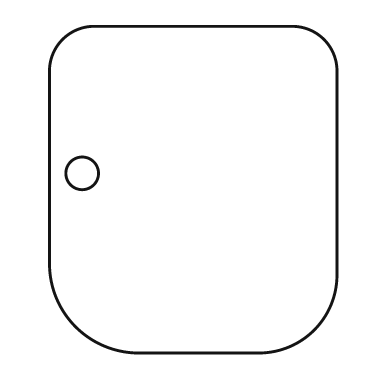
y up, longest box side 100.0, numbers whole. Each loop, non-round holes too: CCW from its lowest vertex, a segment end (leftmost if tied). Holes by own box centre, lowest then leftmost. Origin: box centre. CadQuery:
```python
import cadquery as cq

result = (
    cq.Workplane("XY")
    .moveTo(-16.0, -50.0)
    .lineTo(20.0, -50.0)
    .threePointArc((37.0, -43.0), (44.0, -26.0))
    .lineTo(44.0, 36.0)
    .threePointArc((40.0, 46.0), (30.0, 50.0))
    .lineTo(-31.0, 50.0)
    .threePointArc((-40.0, 46.0), (-44.0, 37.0))
    .lineTo(-44.0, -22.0)
    .threePointArc((-36.0, -42.0), (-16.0, -50.0))
    .close()
    .moveTo(-34.0, 5.0)
    .circle(5.0)
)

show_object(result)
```